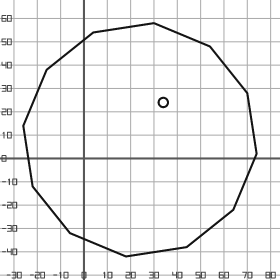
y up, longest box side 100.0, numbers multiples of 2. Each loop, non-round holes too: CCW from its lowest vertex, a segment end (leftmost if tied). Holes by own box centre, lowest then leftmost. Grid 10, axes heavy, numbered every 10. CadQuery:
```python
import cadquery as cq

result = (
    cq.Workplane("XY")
    .moveTo(18.0, -42.0)
    .lineTo(44.0, -38.0)
    .lineTo(64.0, -22.0)
    .lineTo(74.0, 2.0)
    .lineTo(70.0, 28.0)
    .lineTo(54.0, 48.0)
    .lineTo(30.0, 58.0)
    .lineTo(4.0, 54.0)
    .lineTo(-16.0, 38.0)
    .lineTo(-26.0, 14.0)
    .lineTo(-22.0, -12.0)
    .lineTo(-6.0, -32.0)
    .close()
    .moveTo(34.0, 24.0)
    .circle(2.0)
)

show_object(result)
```